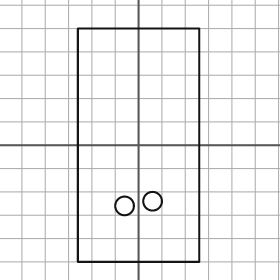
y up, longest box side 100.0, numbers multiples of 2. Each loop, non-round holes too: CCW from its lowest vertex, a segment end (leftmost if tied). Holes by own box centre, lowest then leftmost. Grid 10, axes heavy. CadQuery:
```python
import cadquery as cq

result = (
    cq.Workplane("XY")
    .moveTo(-26.0, -50.0)
    .lineTo(26.0, -50.0)
    .lineTo(26.0, 50.0)
    .lineTo(-26.0, 50.0)
    .close()
    .moveTo(-6.0, -26.0)
    .circle(4.0)
    .moveTo(6.0, -24.0)
    .circle(4.0)
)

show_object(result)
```